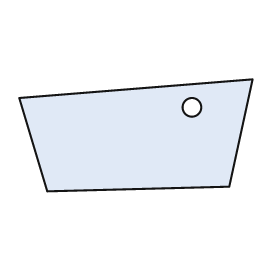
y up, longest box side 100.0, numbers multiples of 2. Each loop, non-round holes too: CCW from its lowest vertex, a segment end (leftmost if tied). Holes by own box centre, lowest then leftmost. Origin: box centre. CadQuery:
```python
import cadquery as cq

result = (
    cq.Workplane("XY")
    .moveTo(-38.0, -24.0)
    .lineTo(40.0, -22.0)
    .lineTo(50.0, 24.0)
    .lineTo(-50.0, 16.0)
    .close()
    .moveTo(24.0, 12.0)
    .circle(4.0)
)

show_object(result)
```